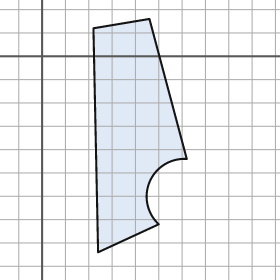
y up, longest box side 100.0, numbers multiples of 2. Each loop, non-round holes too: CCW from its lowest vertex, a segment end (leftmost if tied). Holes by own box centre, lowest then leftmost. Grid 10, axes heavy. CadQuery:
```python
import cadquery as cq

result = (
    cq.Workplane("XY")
    .moveTo(24.0, -84.0)
    .lineTo(50.0, -72.0)
    .threePointArc((46.0, -54.0), (62.0, -44.0))
    .lineTo(46.0, 16.0)
    .lineTo(22.0, 12.0)
    .close()
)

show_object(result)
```